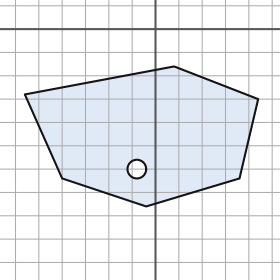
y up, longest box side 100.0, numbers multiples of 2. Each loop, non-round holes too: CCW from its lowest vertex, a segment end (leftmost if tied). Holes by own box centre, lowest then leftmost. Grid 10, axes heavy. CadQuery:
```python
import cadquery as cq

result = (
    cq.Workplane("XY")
    .moveTo(-4.0, -76.0)
    .lineTo(36.0, -64.0)
    .lineTo(44.0, -30.0)
    .lineTo(8.0, -16.0)
    .lineTo(-56.0, -28.0)
    .lineTo(-40.0, -64.0)
    .close()
    .moveTo(-8.0, -60.0)
    .circle(4.0)
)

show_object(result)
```